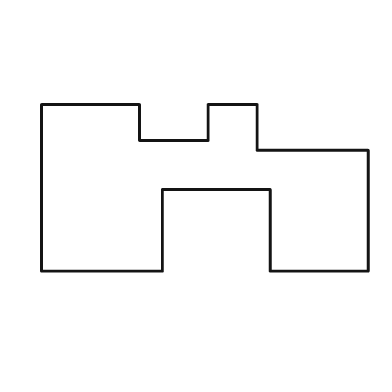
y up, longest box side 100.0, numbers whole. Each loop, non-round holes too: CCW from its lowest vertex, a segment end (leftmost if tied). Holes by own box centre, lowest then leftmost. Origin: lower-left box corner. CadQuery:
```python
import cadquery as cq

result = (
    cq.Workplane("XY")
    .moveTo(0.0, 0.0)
    .lineTo(37.0, 0.0)
    .lineTo(37.0, 25.0)
    .lineTo(70.0, 25.0)
    .lineTo(70.0, 0.0)
    .lineTo(100.0, 0.0)
    .lineTo(100.0, 37.0)
    .lineTo(66.0, 37.0)
    .lineTo(66.0, 51.0)
    .lineTo(51.0, 51.0)
    .lineTo(51.0, 40.0)
    .lineTo(30.0, 40.0)
    .lineTo(30.0, 51.0)
    .lineTo(0.0, 51.0)
    .close()
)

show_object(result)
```